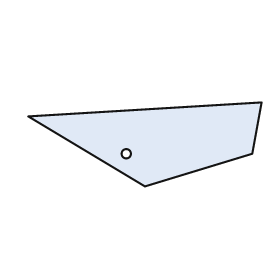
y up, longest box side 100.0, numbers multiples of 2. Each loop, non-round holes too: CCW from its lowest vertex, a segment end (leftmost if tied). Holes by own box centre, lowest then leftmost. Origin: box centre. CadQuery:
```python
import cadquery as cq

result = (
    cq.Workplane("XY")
    .moveTo(0.0, -18.0)
    .lineTo(46.0, -4.0)
    .lineTo(50.0, 18.0)
    .lineTo(-50.0, 12.0)
    .close()
    .moveTo(-8.0, -4.0)
    .circle(2.0)
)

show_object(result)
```